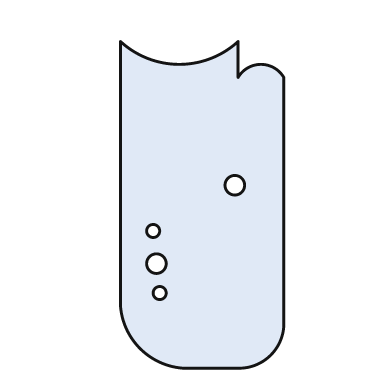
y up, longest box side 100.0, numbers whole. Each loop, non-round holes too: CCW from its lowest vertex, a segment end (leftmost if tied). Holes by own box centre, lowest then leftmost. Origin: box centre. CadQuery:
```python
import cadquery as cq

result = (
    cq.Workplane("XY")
    .moveTo(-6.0, -50.0)
    .lineTo(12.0, -50.0)
    .threePointArc((21.0, -46.0), (25.0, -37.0))
    .lineTo(25.0, 39.0)
    .threePointArc((18.0, 43.0), (11.0, 39.0))
    .lineTo(11.0, 50.0)
    .threePointArc((-7.0, 43.0), (-25.0, 50.0))
    .lineTo(-25.0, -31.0)
    .threePointArc((-19.0, -44.0), (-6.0, -50.0))
    .close()
    .moveTo(-13.0, -27.0)
    .circle(2.0)
    .moveTo(-14.0, -18.0)
    .circle(3.0)
    .moveTo(-15.0, -8.0)
    .circle(2.0)
    .moveTo(10.0, 6.0)
    .circle(3.0)
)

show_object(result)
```